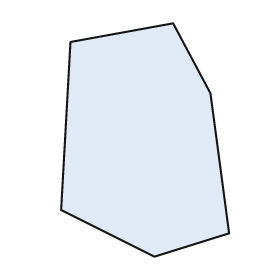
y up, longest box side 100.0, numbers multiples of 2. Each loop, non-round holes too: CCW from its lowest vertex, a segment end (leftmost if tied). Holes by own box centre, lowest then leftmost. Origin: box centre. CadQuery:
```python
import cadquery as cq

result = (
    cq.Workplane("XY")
    .moveTo(4.0, -50.0)
    .lineTo(36.0, -40.0)
    .lineTo(28.0, 20.0)
    .lineTo(12.0, 50.0)
    .lineTo(-32.0, 42.0)
    .lineTo(-36.0, -30.0)
    .close()
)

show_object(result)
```